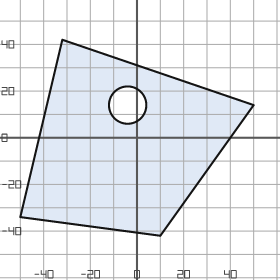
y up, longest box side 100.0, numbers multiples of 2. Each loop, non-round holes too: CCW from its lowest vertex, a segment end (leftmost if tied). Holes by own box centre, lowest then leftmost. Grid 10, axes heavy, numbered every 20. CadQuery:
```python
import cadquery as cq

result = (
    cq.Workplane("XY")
    .moveTo(10.0, -42.0)
    .lineTo(50.0, 14.0)
    .lineTo(-32.0, 42.0)
    .lineTo(-50.0, -34.0)
    .close()
    .moveTo(-4.0, 14.0)
    .circle(8.0)
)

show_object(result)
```